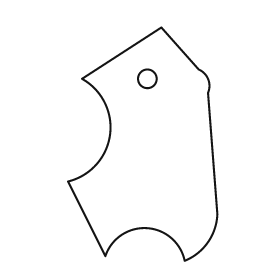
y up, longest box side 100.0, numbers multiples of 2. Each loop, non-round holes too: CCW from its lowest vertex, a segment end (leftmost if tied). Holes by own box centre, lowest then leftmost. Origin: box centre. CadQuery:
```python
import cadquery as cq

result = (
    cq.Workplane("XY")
    .moveTo(18.0, -50.0)
    .threePointArc((28.0, -42.0), (32.0, -30.0))
    .lineTo(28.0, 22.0)
    .threePointArc((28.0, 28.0), (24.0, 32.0))
    .lineTo(8.0, 50.0)
    .lineTo(-26.0, 28.0)
    .threePointArc((-14.0, 4.0), (-32.0, -16.0))
    .lineTo(-16.0, -48.0)
    .threePointArc((2.0, -36.0), (18.0, -50.0))
    .close()
    .moveTo(2.0, 28.0)
    .circle(4.0)
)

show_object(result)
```